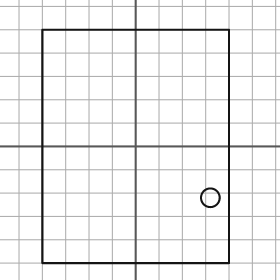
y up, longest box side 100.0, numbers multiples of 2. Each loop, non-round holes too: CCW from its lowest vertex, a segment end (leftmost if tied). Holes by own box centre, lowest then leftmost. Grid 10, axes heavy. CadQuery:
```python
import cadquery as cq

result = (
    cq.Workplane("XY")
    .moveTo(-40.0, -50.0)
    .lineTo(40.0, -50.0)
    .lineTo(40.0, 50.0)
    .lineTo(-40.0, 50.0)
    .close()
    .moveTo(32.0, -22.0)
    .circle(4.0)
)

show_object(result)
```